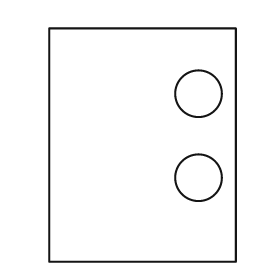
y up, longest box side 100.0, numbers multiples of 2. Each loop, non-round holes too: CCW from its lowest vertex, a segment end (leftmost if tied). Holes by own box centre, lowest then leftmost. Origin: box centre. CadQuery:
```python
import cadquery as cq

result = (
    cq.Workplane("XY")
    .moveTo(-40.0, -50.0)
    .lineTo(40.0, -50.0)
    .lineTo(40.0, 50.0)
    .lineTo(-40.0, 50.0)
    .close()
    .moveTo(24.0, -14.0)
    .circle(10.0)
    .moveTo(24.0, 22.0)
    .circle(10.0)
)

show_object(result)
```